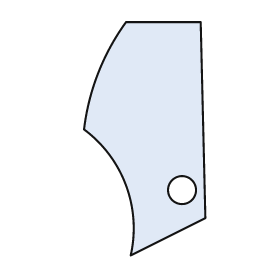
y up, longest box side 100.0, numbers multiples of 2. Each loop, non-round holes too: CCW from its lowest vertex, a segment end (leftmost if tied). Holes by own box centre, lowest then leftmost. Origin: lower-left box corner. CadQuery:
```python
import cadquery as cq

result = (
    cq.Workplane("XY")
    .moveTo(20.0, 0.0)
    .lineTo(52.0, 16.0)
    .lineTo(50.0, 100.0)
    .lineTo(18.0, 100.0)
    .threePointArc((6.0, 78.0), (0.0, 54.0))
    .threePointArc((18.0, 30.0), (20.0, 0.0))
    .close()
    .moveTo(42.0, 28.0)
    .circle(6.0)
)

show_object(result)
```